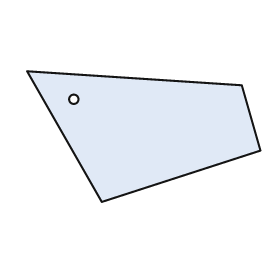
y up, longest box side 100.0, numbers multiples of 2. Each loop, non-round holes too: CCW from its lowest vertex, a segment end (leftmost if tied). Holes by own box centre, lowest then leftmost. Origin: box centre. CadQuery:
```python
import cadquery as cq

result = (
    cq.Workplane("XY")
    .moveTo(-18.0, -28.0)
    .lineTo(50.0, -6.0)
    .lineTo(42.0, 22.0)
    .lineTo(-50.0, 28.0)
    .close()
    .moveTo(-30.0, 16.0)
    .circle(2.0)
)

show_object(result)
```